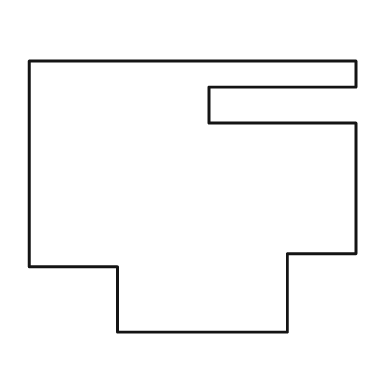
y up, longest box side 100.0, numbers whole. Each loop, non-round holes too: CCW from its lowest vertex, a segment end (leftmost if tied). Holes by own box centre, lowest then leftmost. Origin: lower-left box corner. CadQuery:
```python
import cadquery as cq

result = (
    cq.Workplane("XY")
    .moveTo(27.0, 0.0)
    .lineTo(79.0, 0.0)
    .lineTo(79.0, 24.0)
    .lineTo(100.0, 24.0)
    .lineTo(100.0, 64.0)
    .lineTo(55.0, 64.0)
    .lineTo(55.0, 75.0)
    .lineTo(100.0, 75.0)
    .lineTo(100.0, 83.0)
    .lineTo(0.0, 83.0)
    .lineTo(0.0, 20.0)
    .lineTo(27.0, 20.0)
    .close()
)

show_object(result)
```